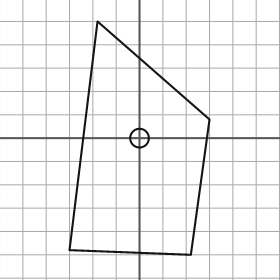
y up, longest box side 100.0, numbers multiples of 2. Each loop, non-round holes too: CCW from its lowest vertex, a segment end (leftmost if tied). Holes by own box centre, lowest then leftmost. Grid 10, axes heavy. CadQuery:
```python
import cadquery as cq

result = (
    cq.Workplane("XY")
    .moveTo(22.0, -50.0)
    .lineTo(30.0, 8.0)
    .lineTo(-18.0, 50.0)
    .lineTo(-30.0, -48.0)
    .close()
    .moveTo(0.0, 0.0)
    .circle(4.0)
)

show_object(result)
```